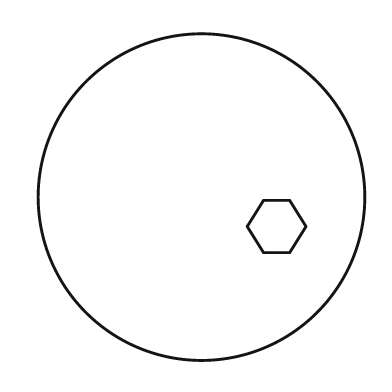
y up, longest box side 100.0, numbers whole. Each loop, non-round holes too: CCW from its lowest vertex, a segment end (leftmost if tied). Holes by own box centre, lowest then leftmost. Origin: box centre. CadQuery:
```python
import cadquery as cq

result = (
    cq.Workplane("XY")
    .moveTo(0.0, 0.0)
    .circle(50.0)
    .moveTo(19.0, -17.0)
    .lineTo(27.0, -17.0)
    .lineTo(32.0, -9.0)
    .lineTo(27.0, -1.0)
    .lineTo(19.0, -1.0)
    .lineTo(14.0, -9.0)
    .close()
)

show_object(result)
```